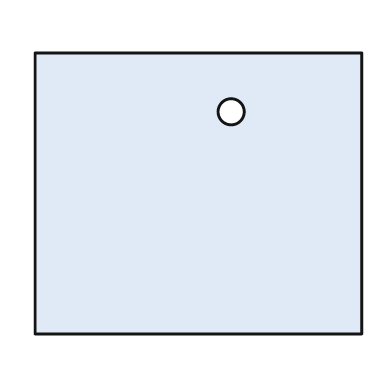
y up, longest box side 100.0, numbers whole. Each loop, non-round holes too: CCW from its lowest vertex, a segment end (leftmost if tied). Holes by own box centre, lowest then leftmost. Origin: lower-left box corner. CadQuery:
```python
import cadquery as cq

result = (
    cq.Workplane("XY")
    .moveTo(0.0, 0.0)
    .lineTo(100.0, 0.0)
    .lineTo(100.0, 86.0)
    .lineTo(0.0, 86.0)
    .close()
    .moveTo(60.0, 68.0)
    .circle(4.0)
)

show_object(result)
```